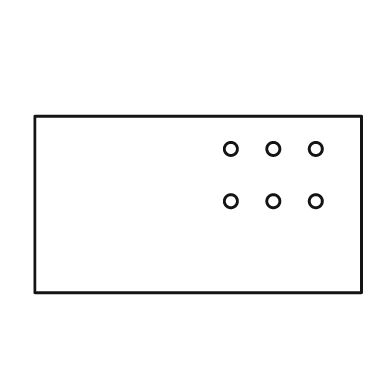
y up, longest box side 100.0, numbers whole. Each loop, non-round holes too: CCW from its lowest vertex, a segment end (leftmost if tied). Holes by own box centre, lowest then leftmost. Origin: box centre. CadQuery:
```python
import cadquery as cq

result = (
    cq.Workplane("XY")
    .moveTo(-50.0, -27.0)
    .lineTo(50.0, -27.0)
    .lineTo(50.0, 27.0)
    .lineTo(-50.0, 27.0)
    .close()
    .moveTo(10.0, 1.0)
    .circle(2.0)
    .moveTo(23.0, 1.0)
    .circle(2.0)
    .moveTo(36.0, 1.0)
    .circle(2.0)
    .moveTo(10.0, 17.0)
    .circle(2.0)
    .moveTo(23.0, 17.0)
    .circle(2.0)
    .moveTo(36.0, 17.0)
    .circle(2.0)
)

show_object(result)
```